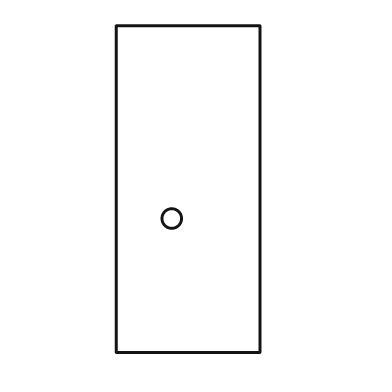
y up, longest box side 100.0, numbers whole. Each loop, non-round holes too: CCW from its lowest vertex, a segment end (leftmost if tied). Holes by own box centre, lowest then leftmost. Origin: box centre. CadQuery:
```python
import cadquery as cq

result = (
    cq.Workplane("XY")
    .moveTo(-22.0, -50.0)
    .lineTo(22.0, -50.0)
    .lineTo(22.0, 50.0)
    .lineTo(-22.0, 50.0)
    .close()
    .moveTo(-5.0, -9.0)
    .circle(3.0)
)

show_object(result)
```